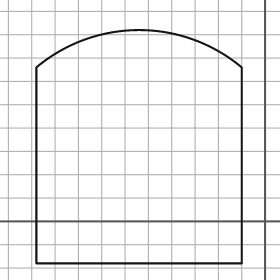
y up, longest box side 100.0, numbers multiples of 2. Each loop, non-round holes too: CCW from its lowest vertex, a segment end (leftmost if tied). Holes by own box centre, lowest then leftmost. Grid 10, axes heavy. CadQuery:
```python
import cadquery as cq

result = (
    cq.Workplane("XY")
    .moveTo(-98.0, -18.0)
    .lineTo(-10.0, -18.0)
    .lineTo(-10.0, 66.0)
    .threePointArc((-54.0, 82.0), (-98.0, 66.0))
    .close()
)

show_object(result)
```